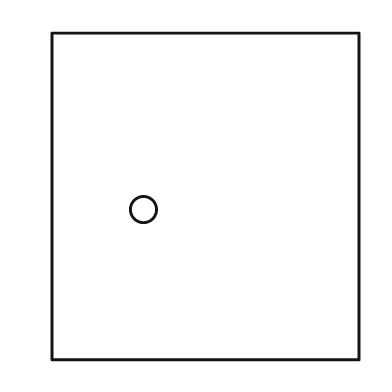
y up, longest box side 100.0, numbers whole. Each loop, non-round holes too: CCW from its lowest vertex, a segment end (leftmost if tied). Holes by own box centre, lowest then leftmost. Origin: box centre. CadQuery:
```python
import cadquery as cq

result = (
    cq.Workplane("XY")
    .moveTo(-47.0, -50.0)
    .lineTo(47.0, -50.0)
    .lineTo(47.0, 50.0)
    .lineTo(-47.0, 50.0)
    .close()
    .moveTo(-19.0, -4.0)
    .circle(4.0)
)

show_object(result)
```